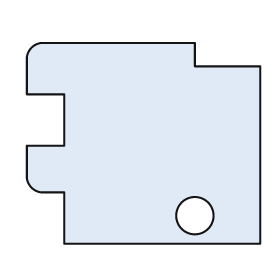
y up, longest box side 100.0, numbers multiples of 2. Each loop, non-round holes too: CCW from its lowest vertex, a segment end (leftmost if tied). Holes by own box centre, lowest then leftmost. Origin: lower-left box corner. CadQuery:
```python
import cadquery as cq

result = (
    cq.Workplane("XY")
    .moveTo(16.0, 0.0)
    .lineTo(100.0, 0.0)
    .lineTo(100.0, 76.0)
    .lineTo(72.0, 76.0)
    .lineTo(72.0, 86.0)
    .lineTo(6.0, 86.0)
    .threePointArc((2.0, 84.0), (0.0, 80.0))
    .lineTo(0.0, 64.0)
    .lineTo(16.0, 64.0)
    .lineTo(16.0, 42.0)
    .lineTo(0.0, 42.0)
    .lineTo(0.0, 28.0)
    .threePointArc((2.0, 24.0), (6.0, 22.0))
    .lineTo(16.0, 22.0)
    .close()
    .moveTo(72.0, 12.0)
    .circle(8.0)
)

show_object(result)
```